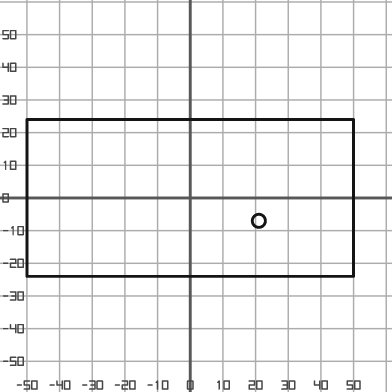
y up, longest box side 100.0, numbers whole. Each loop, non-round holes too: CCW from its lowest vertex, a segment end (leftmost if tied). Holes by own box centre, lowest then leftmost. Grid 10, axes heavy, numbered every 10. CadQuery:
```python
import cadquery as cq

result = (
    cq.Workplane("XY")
    .moveTo(-50.0, -24.0)
    .lineTo(50.0, -24.0)
    .lineTo(50.0, 24.0)
    .lineTo(-50.0, 24.0)
    .close()
    .moveTo(21.0, -7.0)
    .circle(2.0)
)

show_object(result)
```